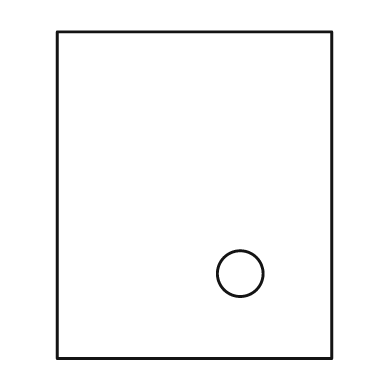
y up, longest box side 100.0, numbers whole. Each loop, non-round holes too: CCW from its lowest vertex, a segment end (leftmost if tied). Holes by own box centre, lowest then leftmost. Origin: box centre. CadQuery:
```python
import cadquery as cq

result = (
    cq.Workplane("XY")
    .moveTo(-42.0, -50.0)
    .lineTo(42.0, -50.0)
    .lineTo(42.0, 50.0)
    .lineTo(-42.0, 50.0)
    .close()
    .moveTo(14.0, -24.0)
    .circle(7.0)
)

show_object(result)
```